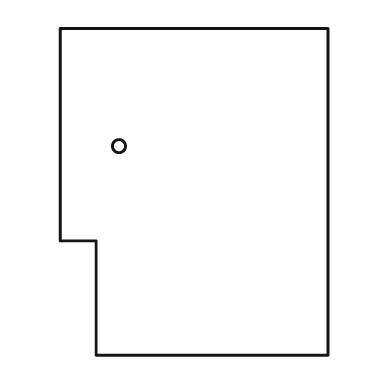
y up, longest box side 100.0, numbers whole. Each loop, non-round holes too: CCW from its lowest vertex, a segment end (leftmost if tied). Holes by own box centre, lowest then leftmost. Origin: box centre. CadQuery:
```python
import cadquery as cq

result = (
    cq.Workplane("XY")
    .moveTo(-30.0, -50.0)
    .lineTo(41.0, -50.0)
    .lineTo(41.0, 50.0)
    .lineTo(-41.0, 50.0)
    .lineTo(-41.0, -15.0)
    .lineTo(-30.0, -15.0)
    .close()
    .moveTo(-23.0, 14.0)
    .circle(2.0)
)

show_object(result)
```